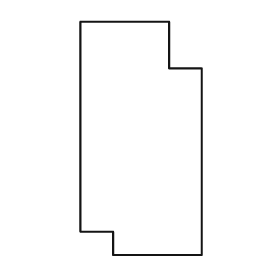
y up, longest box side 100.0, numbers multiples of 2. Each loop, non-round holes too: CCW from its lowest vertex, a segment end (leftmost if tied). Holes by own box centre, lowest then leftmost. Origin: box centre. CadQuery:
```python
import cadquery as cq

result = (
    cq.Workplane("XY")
    .moveTo(-12.0, -50.0)
    .lineTo(26.0, -50.0)
    .lineTo(26.0, 30.0)
    .lineTo(12.0, 30.0)
    .lineTo(12.0, 50.0)
    .lineTo(-26.0, 50.0)
    .lineTo(-26.0, -40.0)
    .lineTo(-12.0, -40.0)
    .close()
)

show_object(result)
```